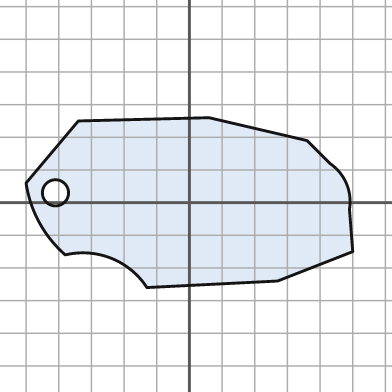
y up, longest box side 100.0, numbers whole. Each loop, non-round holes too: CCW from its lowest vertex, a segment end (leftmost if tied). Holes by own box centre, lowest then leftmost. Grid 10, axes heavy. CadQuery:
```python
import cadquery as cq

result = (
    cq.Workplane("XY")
    .moveTo(-13.0, -26.0)
    .lineTo(27.0, -24.0)
    .lineTo(50.0, -15.0)
    .lineTo(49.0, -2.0)
    .threePointArc((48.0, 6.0), (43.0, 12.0))
    .lineTo(36.0, 19.0)
    .lineTo(6.0, 26.0)
    .lineTo(-34.0, 25.0)
    .lineTo(-50.0, 6.0)
    .threePointArc((-46.0, -6.0), (-38.0, -16.0))
    .threePointArc((-24.0, -17.0), (-13.0, -26.0))
    .close()
    .moveTo(-41.0, 3.0)
    .circle(4.0)
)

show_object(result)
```